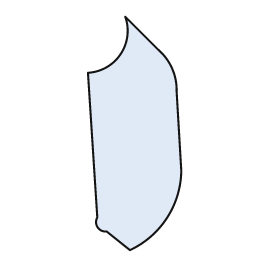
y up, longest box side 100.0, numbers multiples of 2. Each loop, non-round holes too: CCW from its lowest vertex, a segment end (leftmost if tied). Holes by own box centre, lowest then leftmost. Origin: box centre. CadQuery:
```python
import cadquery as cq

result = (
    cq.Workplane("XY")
    .moveTo(-2.0, -50.0)
    .threePointArc((14.0, -36.0), (20.0, -16.0))
    .lineTo(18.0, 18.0)
    .threePointArc((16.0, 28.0), (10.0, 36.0))
    .lineTo(-4.0, 50.0)
    .threePointArc((-6.0, 34.0), (-20.0, 26.0))
    .lineTo(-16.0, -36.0)
    .threePointArc((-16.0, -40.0), (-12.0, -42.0))
    .close()
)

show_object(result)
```